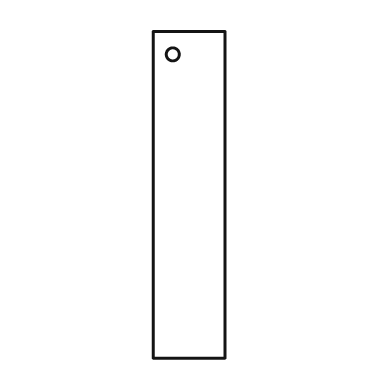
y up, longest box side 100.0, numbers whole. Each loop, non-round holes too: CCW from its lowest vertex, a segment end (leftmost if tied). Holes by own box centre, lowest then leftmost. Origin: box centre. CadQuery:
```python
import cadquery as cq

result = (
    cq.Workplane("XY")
    .moveTo(-11.0, -50.0)
    .lineTo(11.0, -50.0)
    .lineTo(11.0, 50.0)
    .lineTo(-11.0, 50.0)
    .close()
    .moveTo(-5.0, 43.0)
    .circle(2.0)
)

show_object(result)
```